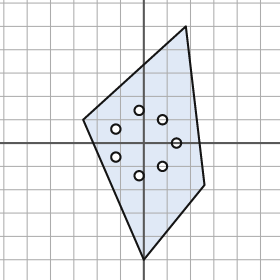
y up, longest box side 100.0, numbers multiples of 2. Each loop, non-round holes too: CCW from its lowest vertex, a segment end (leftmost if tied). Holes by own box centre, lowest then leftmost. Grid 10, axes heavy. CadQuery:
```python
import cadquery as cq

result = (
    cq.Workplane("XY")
    .moveTo(0.0, -50.0)
    .lineTo(26.0, -18.0)
    .lineTo(18.0, 50.0)
    .lineTo(-26.0, 10.0)
    .close()
    .moveTo(-2.0, -14.0)
    .circle(2.0)
    .moveTo(8.0, -10.0)
    .circle(2.0)
    .moveTo(-12.0, -6.0)
    .circle(2.0)
    .moveTo(14.0, 0.0)
    .circle(2.0)
    .moveTo(-12.0, 6.0)
    .circle(2.0)
    .moveTo(8.0, 10.0)
    .circle(2.0)
    .moveTo(-2.0, 14.0)
    .circle(2.0)
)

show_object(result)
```